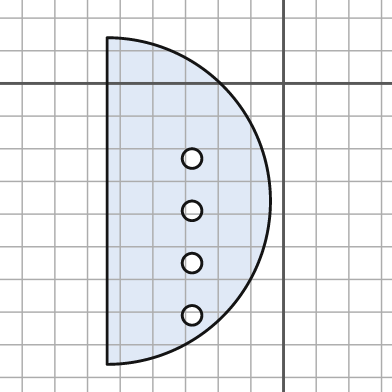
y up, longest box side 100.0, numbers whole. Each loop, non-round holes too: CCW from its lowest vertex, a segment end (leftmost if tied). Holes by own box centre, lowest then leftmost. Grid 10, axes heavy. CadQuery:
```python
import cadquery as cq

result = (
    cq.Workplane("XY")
    .moveTo(-54.0, -86.0)
    .threePointArc((-4.0, -36.0), (-54.0, 14.0))
    .close()
    .moveTo(-28.0, -71.0)
    .circle(3.0)
    .moveTo(-28.0, -55.0)
    .circle(3.0)
    .moveTo(-28.0, -39.0)
    .circle(3.0)
    .moveTo(-28.0, -23.0)
    .circle(3.0)
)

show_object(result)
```